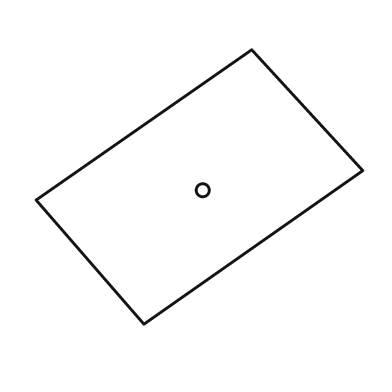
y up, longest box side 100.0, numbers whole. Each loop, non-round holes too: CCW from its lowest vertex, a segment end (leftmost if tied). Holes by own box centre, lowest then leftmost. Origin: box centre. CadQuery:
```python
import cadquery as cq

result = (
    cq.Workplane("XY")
    .moveTo(-17.0, -42.0)
    .lineTo(50.0, 5.0)
    .lineTo(16.0, 42.0)
    .lineTo(-50.0, -4.0)
    .close()
    .moveTo(1.0, -1.0)
    .circle(2.0)
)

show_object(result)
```